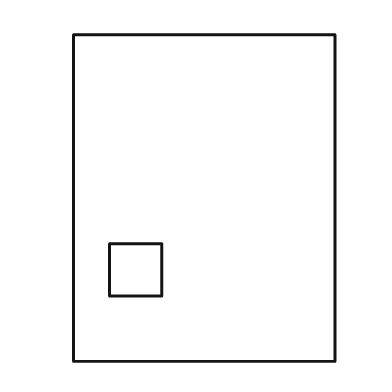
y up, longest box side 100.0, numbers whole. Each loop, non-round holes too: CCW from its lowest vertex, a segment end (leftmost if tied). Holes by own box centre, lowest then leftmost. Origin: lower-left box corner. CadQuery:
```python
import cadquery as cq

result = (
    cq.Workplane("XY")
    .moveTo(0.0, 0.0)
    .lineTo(80.0, 0.0)
    .lineTo(80.0, 100.0)
    .lineTo(0.0, 100.0)
    .close()
    .moveTo(11.0, 20.0)
    .lineTo(27.0, 20.0)
    .lineTo(27.0, 36.0)
    .lineTo(11.0, 36.0)
    .close()
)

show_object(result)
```